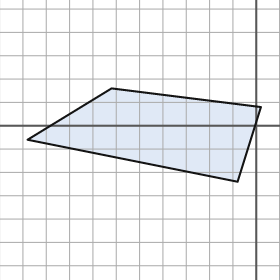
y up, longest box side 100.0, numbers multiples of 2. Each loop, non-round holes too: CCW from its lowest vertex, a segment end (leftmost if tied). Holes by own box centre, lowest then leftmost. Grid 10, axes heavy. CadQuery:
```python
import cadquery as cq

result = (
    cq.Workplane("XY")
    .moveTo(-8.0, -24.0)
    .lineTo(2.0, 8.0)
    .lineTo(-62.0, 16.0)
    .lineTo(-98.0, -6.0)
    .close()
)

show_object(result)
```